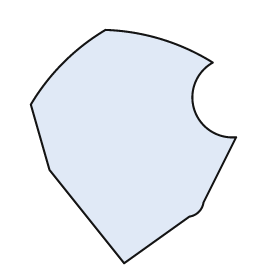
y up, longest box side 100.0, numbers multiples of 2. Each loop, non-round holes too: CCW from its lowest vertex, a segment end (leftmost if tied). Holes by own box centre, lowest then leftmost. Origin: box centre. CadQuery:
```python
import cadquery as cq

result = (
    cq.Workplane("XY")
    .moveTo(-4.0, -50.0)
    .lineTo(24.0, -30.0)
    .threePointArc((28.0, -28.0), (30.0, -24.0))
    .lineTo(44.0, 4.0)
    .threePointArc((26.0, 16.0), (34.0, 36.0))
    .threePointArc((12.0, 46.0), (-12.0, 50.0))
    .threePointArc((-30.0, 36.0), (-44.0, 18.0))
    .lineTo(-36.0, -10.0)
    .close()
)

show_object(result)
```